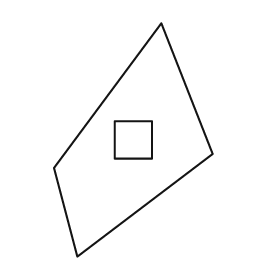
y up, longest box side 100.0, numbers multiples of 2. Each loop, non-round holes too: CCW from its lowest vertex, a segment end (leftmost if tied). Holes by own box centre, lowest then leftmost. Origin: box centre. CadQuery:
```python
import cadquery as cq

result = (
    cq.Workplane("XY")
    .moveTo(-24.0, -50.0)
    .lineTo(34.0, -6.0)
    .lineTo(12.0, 50.0)
    .lineTo(-34.0, -12.0)
    .close()
    .moveTo(-8.0, -8.0)
    .lineTo(8.0, -8.0)
    .lineTo(8.0, 8.0)
    .lineTo(-8.0, 8.0)
    .close()
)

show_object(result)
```